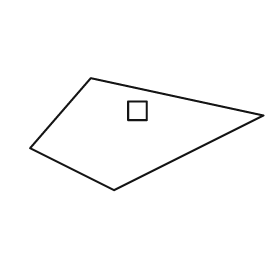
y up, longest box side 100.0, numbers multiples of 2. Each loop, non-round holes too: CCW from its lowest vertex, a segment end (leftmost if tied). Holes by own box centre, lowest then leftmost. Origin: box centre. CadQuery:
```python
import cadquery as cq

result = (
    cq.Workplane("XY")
    .moveTo(-14.0, -24.0)
    .lineTo(50.0, 8.0)
    .lineTo(-24.0, 24.0)
    .lineTo(-50.0, -6.0)
    .close()
    .moveTo(-8.0, 6.0)
    .lineTo(0.0, 6.0)
    .lineTo(0.0, 14.0)
    .lineTo(-8.0, 14.0)
    .close()
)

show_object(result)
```